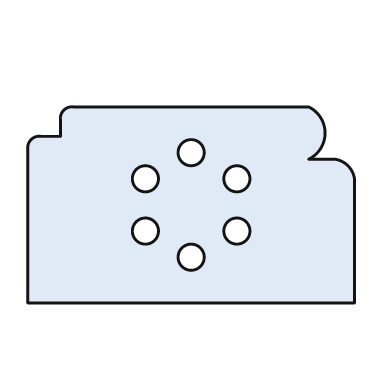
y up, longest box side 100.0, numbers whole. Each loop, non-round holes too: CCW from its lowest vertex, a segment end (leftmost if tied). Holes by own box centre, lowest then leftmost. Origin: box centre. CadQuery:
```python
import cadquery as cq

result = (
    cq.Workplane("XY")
    .moveTo(-50.0, -30.0)
    .lineTo(50.0, -30.0)
    .lineTo(50.0, 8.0)
    .threePointArc((48.0, 12.0), (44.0, 14.0))
    .lineTo(36.0, 14.0)
    .threePointArc((41.0, 22.0), (36.0, 30.0))
    .lineTo(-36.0, 30.0)
    .threePointArc((-39.0, 29.0), (-40.0, 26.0))
    .lineTo(-40.0, 21.0)
    .lineTo(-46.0, 21.0)
    .threePointArc((-49.0, 20.0), (-50.0, 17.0))
    .close()
    .moveTo(0.0, -16.0)
    .circle(4.0)
    .moveTo(-14.0, -8.0)
    .circle(4.0)
    .moveTo(14.0, -8.0)
    .circle(4.0)
    .moveTo(-14.0, 8.0)
    .circle(4.0)
    .moveTo(14.0, 8.0)
    .circle(4.0)
    .moveTo(0.0, 16.0)
    .circle(4.0)
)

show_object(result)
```